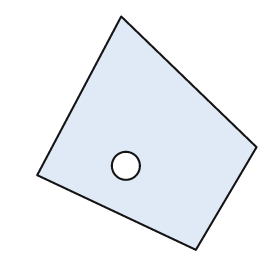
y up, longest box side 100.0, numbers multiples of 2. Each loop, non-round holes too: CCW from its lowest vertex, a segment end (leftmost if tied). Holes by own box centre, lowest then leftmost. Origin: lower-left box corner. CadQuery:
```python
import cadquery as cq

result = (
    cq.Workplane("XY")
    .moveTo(68.0, 0.0)
    .lineTo(94.0, 44.0)
    .lineTo(36.0, 100.0)
    .lineTo(0.0, 32.0)
    .close()
    .moveTo(38.0, 36.0)
    .circle(6.0)
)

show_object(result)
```